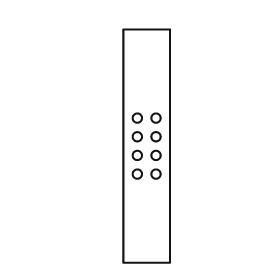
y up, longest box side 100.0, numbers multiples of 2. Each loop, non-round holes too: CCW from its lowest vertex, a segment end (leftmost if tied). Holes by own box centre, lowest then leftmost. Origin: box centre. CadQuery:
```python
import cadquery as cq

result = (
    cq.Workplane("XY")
    .moveTo(-10.0, -50.0)
    .lineTo(10.0, -50.0)
    .lineTo(10.0, 50.0)
    .lineTo(-10.0, 50.0)
    .close()
    .moveTo(-4.0, -12.0)
    .circle(2.0)
    .moveTo(4.0, -12.0)
    .circle(2.0)
    .moveTo(-4.0, -4.0)
    .circle(2.0)
    .moveTo(4.0, -4.0)
    .circle(2.0)
    .moveTo(-4.0, 4.0)
    .circle(2.0)
    .moveTo(4.0, 4.0)
    .circle(2.0)
    .moveTo(-4.0, 12.0)
    .circle(2.0)
    .moveTo(4.0, 12.0)
    .circle(2.0)
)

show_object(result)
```